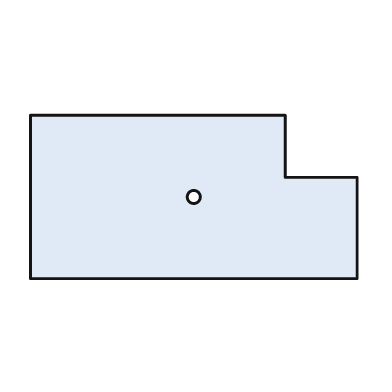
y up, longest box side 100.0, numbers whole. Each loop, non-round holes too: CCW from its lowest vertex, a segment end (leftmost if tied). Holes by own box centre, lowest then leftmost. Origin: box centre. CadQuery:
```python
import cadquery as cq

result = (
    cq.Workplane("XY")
    .moveTo(-50.0, -25.0)
    .lineTo(50.0, -25.0)
    .lineTo(50.0, 6.0)
    .lineTo(28.0, 6.0)
    .lineTo(28.0, 25.0)
    .lineTo(-50.0, 25.0)
    .close()
    .moveTo(0.0, 0.0)
    .circle(2.0)
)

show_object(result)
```